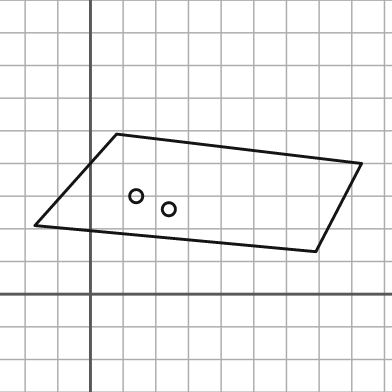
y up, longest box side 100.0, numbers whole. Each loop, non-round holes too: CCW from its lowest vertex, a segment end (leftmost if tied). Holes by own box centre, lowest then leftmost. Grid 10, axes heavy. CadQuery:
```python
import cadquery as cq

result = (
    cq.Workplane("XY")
    .moveTo(69.0, 13.0)
    .lineTo(83.0, 40.0)
    .lineTo(8.0, 49.0)
    .lineTo(-17.0, 21.0)
    .close()
    .moveTo(24.0, 26.0)
    .circle(2.0)
    .moveTo(14.0, 30.0)
    .circle(2.0)
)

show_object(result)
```